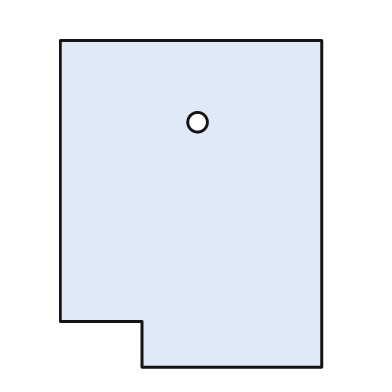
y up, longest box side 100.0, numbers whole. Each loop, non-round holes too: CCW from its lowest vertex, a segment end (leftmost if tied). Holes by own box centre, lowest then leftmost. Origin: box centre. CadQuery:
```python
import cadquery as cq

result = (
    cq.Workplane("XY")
    .moveTo(-15.0, -50.0)
    .lineTo(40.0, -50.0)
    .lineTo(40.0, 50.0)
    .lineTo(-40.0, 50.0)
    .lineTo(-40.0, -36.0)
    .lineTo(-15.0, -36.0)
    .close()
    .moveTo(2.0, 25.0)
    .circle(3.0)
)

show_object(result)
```